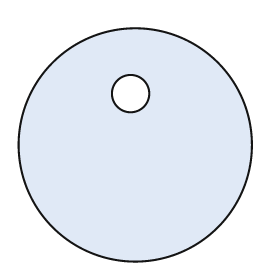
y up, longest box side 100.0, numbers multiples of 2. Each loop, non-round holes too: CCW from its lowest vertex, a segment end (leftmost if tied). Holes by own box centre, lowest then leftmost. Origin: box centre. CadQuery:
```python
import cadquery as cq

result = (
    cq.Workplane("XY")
    .moveTo(0.0, 0.0)
    .circle(50.0)
    .moveTo(-2.0, 22.0)
    .circle(8.0)
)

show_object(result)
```